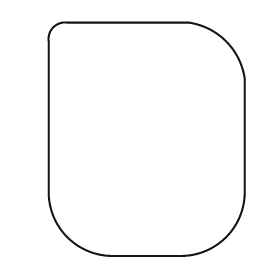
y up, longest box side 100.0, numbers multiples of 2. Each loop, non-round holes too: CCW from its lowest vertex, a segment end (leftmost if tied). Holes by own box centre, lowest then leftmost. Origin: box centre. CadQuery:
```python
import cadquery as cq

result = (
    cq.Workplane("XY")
    .moveTo(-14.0, -50.0)
    .lineTo(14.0, -50.0)
    .threePointArc((34.0, -42.0), (42.0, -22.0))
    .lineTo(42.0, 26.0)
    .threePointArc((34.0, 42.0), (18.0, 50.0))
    .lineTo(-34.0, 50.0)
    .threePointArc((-40.0, 48.0), (-42.0, 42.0))
    .lineTo(-42.0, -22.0)
    .threePointArc((-34.0, -42.0), (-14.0, -50.0))
    .close()
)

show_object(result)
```